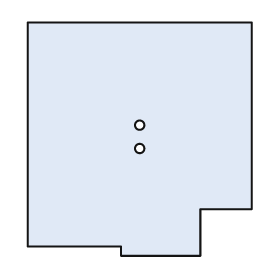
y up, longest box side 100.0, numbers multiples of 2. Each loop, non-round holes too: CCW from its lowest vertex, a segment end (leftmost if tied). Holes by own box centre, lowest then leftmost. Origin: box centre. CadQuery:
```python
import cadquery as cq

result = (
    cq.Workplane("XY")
    .moveTo(-8.0, -50.0)
    .lineTo(26.0, -50.0)
    .lineTo(26.0, -30.0)
    .lineTo(48.0, -30.0)
    .lineTo(48.0, 50.0)
    .lineTo(-48.0, 50.0)
    .lineTo(-48.0, -46.0)
    .lineTo(-8.0, -46.0)
    .close()
    .moveTo(0.0, -4.0)
    .circle(2.0)
    .moveTo(0.0, 6.0)
    .circle(2.0)
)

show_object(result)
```